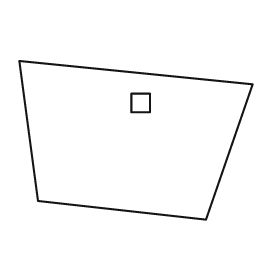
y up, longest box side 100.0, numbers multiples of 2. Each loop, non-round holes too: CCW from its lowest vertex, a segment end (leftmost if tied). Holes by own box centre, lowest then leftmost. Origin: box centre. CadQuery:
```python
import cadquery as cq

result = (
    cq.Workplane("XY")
    .moveTo(30.0, -34.0)
    .lineTo(50.0, 24.0)
    .lineTo(-50.0, 34.0)
    .lineTo(-42.0, -26.0)
    .close()
    .moveTo(-2.0, 12.0)
    .lineTo(6.0, 12.0)
    .lineTo(6.0, 20.0)
    .lineTo(-2.0, 20.0)
    .close()
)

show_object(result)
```